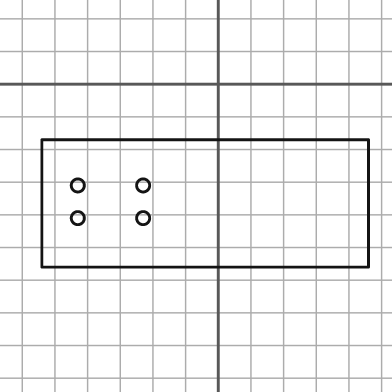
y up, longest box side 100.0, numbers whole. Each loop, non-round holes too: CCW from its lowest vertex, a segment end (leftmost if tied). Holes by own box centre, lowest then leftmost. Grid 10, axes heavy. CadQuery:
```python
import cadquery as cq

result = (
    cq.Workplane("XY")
    .moveTo(-54.0, -56.0)
    .lineTo(46.0, -56.0)
    .lineTo(46.0, -17.0)
    .lineTo(-54.0, -17.0)
    .close()
    .moveTo(-43.0, -41.0)
    .circle(2.0)
    .moveTo(-23.0, -41.0)
    .circle(2.0)
    .moveTo(-43.0, -31.0)
    .circle(2.0)
    .moveTo(-23.0, -31.0)
    .circle(2.0)
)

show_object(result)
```